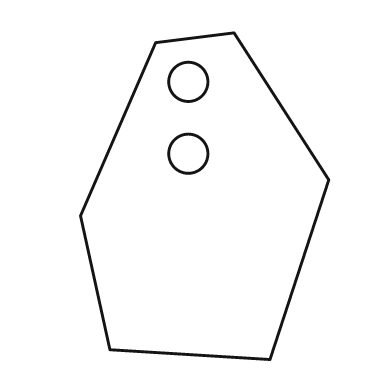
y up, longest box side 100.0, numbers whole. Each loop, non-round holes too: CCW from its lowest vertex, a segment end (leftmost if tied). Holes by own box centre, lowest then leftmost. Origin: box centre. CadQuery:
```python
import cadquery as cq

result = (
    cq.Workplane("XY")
    .moveTo(20.0, -50.0)
    .lineTo(38.0, 5.0)
    .lineTo(9.0, 50.0)
    .lineTo(-15.0, 47.0)
    .lineTo(-38.0, -6.0)
    .lineTo(-29.0, -47.0)
    .close()
    .moveTo(-5.0, 13.0)
    .circle(6.0)
    .moveTo(-5.0, 35.0)
    .circle(6.0)
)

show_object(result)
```